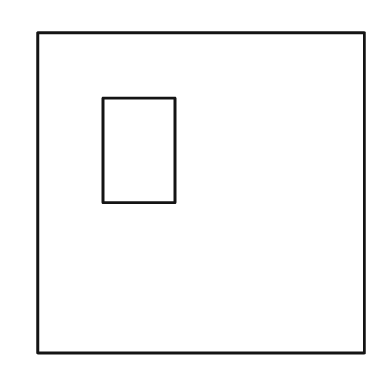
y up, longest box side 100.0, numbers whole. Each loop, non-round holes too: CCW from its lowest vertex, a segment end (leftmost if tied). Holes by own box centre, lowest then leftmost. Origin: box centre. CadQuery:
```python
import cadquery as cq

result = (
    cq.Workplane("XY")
    .moveTo(-50.0, -49.0)
    .lineTo(50.0, -49.0)
    .lineTo(50.0, 49.0)
    .lineTo(-50.0, 49.0)
    .close()
    .moveTo(-30.0, -3.0)
    .lineTo(-8.0, -3.0)
    .lineTo(-8.0, 29.0)
    .lineTo(-30.0, 29.0)
    .close()
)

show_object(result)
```